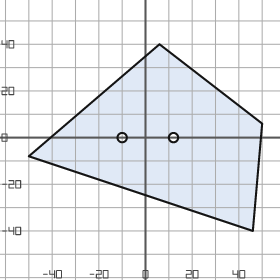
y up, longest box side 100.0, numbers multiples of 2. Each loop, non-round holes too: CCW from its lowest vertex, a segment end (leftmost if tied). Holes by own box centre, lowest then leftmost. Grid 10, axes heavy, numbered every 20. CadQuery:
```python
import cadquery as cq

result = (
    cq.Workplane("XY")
    .moveTo(46.0, -40.0)
    .lineTo(50.0, 6.0)
    .lineTo(6.0, 40.0)
    .lineTo(-50.0, -8.0)
    .close()
    .moveTo(-10.0, 0.0)
    .circle(2.0)
    .moveTo(12.0, 0.0)
    .circle(2.0)
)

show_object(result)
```